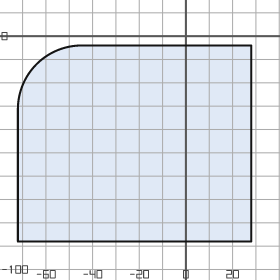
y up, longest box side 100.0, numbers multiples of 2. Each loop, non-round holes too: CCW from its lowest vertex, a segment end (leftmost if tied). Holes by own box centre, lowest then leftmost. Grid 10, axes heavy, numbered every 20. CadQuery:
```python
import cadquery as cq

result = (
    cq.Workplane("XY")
    .moveTo(-72.0, -88.0)
    .lineTo(28.0, -88.0)
    .lineTo(28.0, -4.0)
    .lineTo(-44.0, -4.0)
    .threePointArc((-64.0, -12.0), (-72.0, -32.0))
    .close()
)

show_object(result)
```